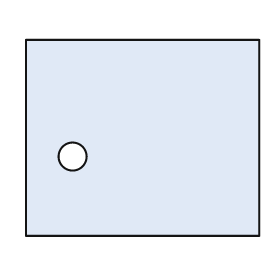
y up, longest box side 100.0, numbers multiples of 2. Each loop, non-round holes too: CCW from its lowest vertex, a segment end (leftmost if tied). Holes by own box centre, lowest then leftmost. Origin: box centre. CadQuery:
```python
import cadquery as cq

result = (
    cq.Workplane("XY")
    .moveTo(-50.0, -42.0)
    .lineTo(50.0, -42.0)
    .lineTo(50.0, 42.0)
    .lineTo(-50.0, 42.0)
    .close()
    .moveTo(-30.0, -8.0)
    .circle(6.0)
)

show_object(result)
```